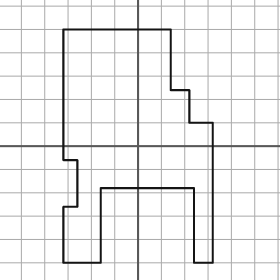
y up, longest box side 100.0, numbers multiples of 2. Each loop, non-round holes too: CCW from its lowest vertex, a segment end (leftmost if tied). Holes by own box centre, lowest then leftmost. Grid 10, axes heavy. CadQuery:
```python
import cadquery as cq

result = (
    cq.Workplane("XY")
    .moveTo(-32.0, -50.0)
    .lineTo(-16.0, -50.0)
    .lineTo(-16.0, -18.0)
    .lineTo(24.0, -18.0)
    .lineTo(24.0, -50.0)
    .lineTo(32.0, -50.0)
    .lineTo(32.0, 10.0)
    .lineTo(22.0, 10.0)
    .lineTo(22.0, 24.0)
    .lineTo(14.0, 24.0)
    .lineTo(14.0, 50.0)
    .lineTo(-32.0, 50.0)
    .lineTo(-32.0, -6.0)
    .lineTo(-26.0, -6.0)
    .lineTo(-26.0, -26.0)
    .lineTo(-32.0, -26.0)
    .close()
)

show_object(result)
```